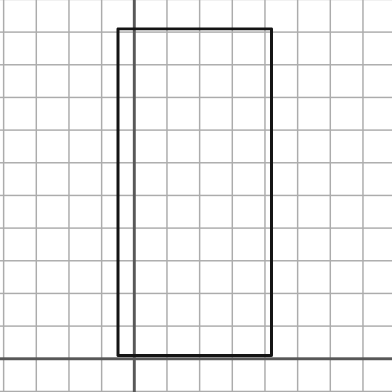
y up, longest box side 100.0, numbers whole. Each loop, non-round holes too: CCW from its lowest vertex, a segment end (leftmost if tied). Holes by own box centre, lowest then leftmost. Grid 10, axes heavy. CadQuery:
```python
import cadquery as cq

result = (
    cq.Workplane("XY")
    .moveTo(-5.0, 1.0)
    .lineTo(42.0, 1.0)
    .lineTo(42.0, 101.0)
    .lineTo(-5.0, 101.0)
    .close()
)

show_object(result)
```